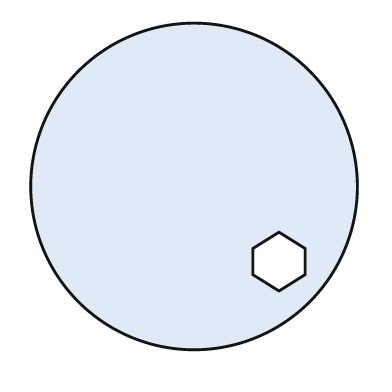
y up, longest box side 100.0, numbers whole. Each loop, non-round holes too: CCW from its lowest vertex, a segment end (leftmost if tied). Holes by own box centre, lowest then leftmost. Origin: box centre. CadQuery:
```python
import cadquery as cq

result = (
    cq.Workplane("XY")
    .moveTo(0.0, 0.0)
    .circle(50.0)
    .moveTo(26.0, -32.0)
    .lineTo(34.0, -27.0)
    .lineTo(34.0, -19.0)
    .lineTo(26.0, -14.0)
    .lineTo(18.0, -19.0)
    .lineTo(18.0, -27.0)
    .close()
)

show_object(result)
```